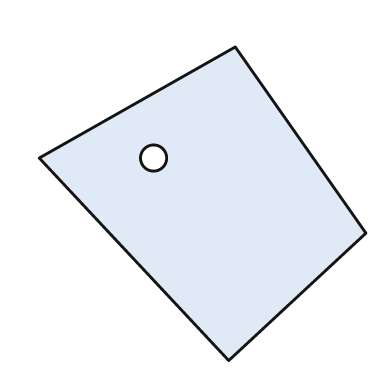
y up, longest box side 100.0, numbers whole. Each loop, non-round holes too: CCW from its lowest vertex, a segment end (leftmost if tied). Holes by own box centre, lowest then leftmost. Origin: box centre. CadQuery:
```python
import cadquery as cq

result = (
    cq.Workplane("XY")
    .moveTo(8.0, -48.0)
    .lineTo(50.0, -9.0)
    .lineTo(10.0, 48.0)
    .lineTo(-50.0, 14.0)
    .close()
    .moveTo(-15.0, 14.0)
    .circle(4.0)
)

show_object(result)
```